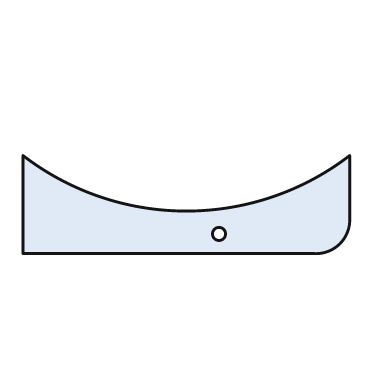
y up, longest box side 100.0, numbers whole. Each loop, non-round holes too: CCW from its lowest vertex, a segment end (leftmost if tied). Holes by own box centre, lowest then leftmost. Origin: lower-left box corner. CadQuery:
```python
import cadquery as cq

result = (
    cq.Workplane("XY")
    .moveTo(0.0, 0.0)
    .lineTo(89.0, 0.0)
    .threePointArc((97.0, 3.0), (100.0, 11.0))
    .lineTo(100.0, 30.0)
    .threePointArc((50.0, 13.0), (0.0, 30.0))
    .close()
    .moveTo(60.0, 6.0)
    .circle(2.0)
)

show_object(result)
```